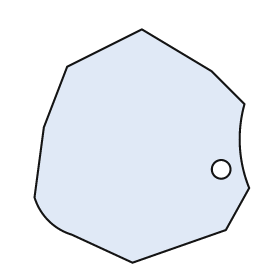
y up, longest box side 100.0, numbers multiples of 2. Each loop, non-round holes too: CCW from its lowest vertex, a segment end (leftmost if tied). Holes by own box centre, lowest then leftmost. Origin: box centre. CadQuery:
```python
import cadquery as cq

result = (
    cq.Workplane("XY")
    .moveTo(-4.0, -50.0)
    .lineTo(36.0, -36.0)
    .lineTo(46.0, -18.0)
    .threePointArc((42.0, 0.0), (44.0, 18.0))
    .lineTo(30.0, 32.0)
    .lineTo(0.0, 50.0)
    .lineTo(-32.0, 34.0)
    .lineTo(-42.0, 8.0)
    .lineTo(-46.0, -22.0)
    .threePointArc((-40.0, -32.0), (-30.0, -38.0))
    .close()
    .moveTo(34.0, -10.0)
    .circle(4.0)
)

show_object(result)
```